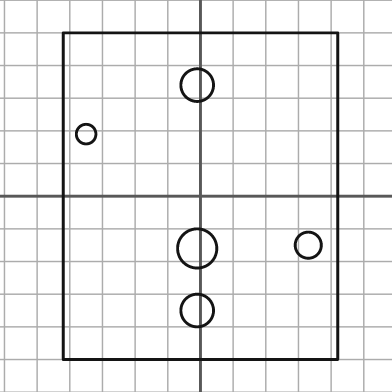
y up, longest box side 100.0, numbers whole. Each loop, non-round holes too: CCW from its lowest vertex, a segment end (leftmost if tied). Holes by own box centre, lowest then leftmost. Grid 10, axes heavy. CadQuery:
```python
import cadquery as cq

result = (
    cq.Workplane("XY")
    .moveTo(-42.0, -50.0)
    .lineTo(42.0, -50.0)
    .lineTo(42.0, 50.0)
    .lineTo(-42.0, 50.0)
    .close()
    .moveTo(-1.0, -35.0)
    .circle(5.0)
    .moveTo(-1.0, -16.0)
    .circle(6.0)
    .moveTo(33.0, -15.0)
    .circle(4.0)
    .moveTo(-35.0, 19.0)
    .circle(3.0)
    .moveTo(-1.0, 34.0)
    .circle(5.0)
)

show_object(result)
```